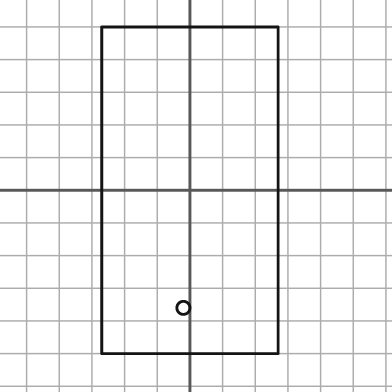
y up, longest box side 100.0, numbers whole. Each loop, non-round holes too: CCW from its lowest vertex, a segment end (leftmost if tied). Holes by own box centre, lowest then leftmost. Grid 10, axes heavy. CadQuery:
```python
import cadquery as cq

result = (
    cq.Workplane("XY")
    .moveTo(-27.0, -50.0)
    .lineTo(27.0, -50.0)
    .lineTo(27.0, 50.0)
    .lineTo(-27.0, 50.0)
    .close()
    .moveTo(-2.0, -36.0)
    .circle(2.0)
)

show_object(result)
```